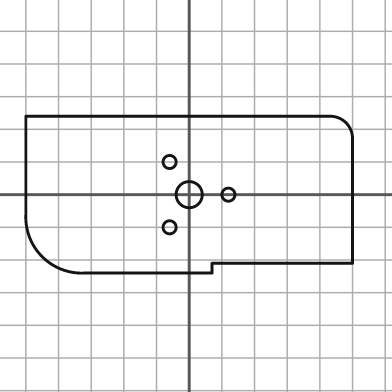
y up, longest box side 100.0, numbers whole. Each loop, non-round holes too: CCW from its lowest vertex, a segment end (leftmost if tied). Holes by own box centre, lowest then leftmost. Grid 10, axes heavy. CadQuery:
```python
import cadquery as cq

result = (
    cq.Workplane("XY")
    .moveTo(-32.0, -24.0)
    .lineTo(7.0, -24.0)
    .lineTo(7.0, -21.0)
    .lineTo(50.0, -21.0)
    .lineTo(50.0, 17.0)
    .threePointArc((48.0, 22.0), (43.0, 24.0))
    .lineTo(-50.0, 24.0)
    .lineTo(-50.0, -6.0)
    .threePointArc((-45.0, -19.0), (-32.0, -24.0))
    .close()
    .moveTo(-6.0, -10.0)
    .circle(2.0)
    .moveTo(0.0, 0.0)
    .circle(4.0)
    .moveTo(12.0, 0.0)
    .circle(2.0)
    .moveTo(-6.0, 10.0)
    .circle(2.0)
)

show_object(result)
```